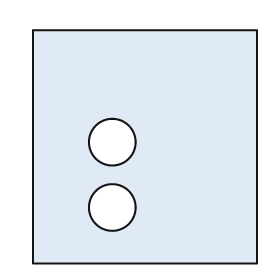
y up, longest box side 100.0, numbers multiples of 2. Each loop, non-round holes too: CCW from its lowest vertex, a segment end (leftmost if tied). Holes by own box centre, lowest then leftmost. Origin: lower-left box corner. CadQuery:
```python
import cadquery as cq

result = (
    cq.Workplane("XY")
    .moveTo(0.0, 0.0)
    .lineTo(96.0, 0.0)
    .lineTo(96.0, 100.0)
    .lineTo(0.0, 100.0)
    .close()
    .moveTo(34.0, 24.0)
    .circle(10.0)
    .moveTo(34.0, 52.0)
    .circle(10.0)
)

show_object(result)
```